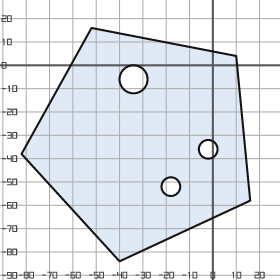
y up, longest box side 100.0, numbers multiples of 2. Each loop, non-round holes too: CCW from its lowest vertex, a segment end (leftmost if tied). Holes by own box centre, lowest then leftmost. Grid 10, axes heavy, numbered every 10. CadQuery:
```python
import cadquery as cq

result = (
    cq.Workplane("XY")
    .moveTo(-40.0, -84.0)
    .lineTo(16.0, -58.0)
    .lineTo(10.0, 4.0)
    .lineTo(-52.0, 16.0)
    .lineTo(-82.0, -38.0)
    .close()
    .moveTo(-18.0, -52.0)
    .circle(4.0)
    .moveTo(-2.0, -36.0)
    .circle(4.0)
    .moveTo(-34.0, -6.0)
    .circle(6.0)
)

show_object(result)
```